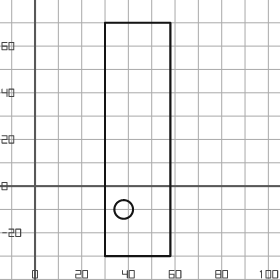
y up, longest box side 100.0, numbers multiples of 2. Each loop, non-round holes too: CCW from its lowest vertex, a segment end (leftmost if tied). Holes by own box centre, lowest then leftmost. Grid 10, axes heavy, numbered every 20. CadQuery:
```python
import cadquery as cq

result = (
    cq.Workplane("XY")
    .moveTo(30.0, -30.0)
    .lineTo(58.0, -30.0)
    .lineTo(58.0, 70.0)
    .lineTo(30.0, 70.0)
    .close()
    .moveTo(38.0, -10.0)
    .circle(4.0)
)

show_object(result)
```